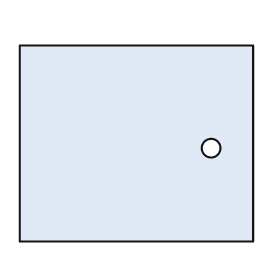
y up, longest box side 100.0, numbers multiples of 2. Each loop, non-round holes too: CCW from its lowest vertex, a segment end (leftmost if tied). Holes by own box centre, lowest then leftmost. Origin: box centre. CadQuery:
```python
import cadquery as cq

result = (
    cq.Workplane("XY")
    .moveTo(-50.0, -42.0)
    .lineTo(50.0, -42.0)
    .lineTo(50.0, 42.0)
    .lineTo(-50.0, 42.0)
    .close()
    .moveTo(32.0, -2.0)
    .circle(4.0)
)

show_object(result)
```